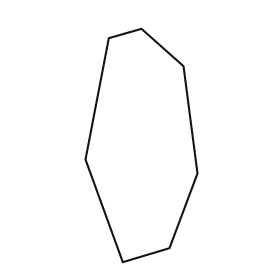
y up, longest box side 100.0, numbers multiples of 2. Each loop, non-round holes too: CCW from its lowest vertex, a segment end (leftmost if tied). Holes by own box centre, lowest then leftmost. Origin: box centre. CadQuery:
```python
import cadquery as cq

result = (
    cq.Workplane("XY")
    .moveTo(-8.0, -50.0)
    .lineTo(12.0, -44.0)
    .lineTo(24.0, -12.0)
    .lineTo(18.0, 34.0)
    .lineTo(0.0, 50.0)
    .lineTo(-14.0, 46.0)
    .lineTo(-24.0, -6.0)
    .close()
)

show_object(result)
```